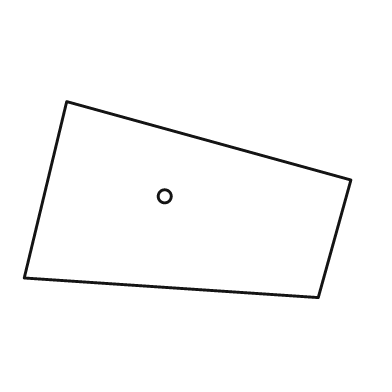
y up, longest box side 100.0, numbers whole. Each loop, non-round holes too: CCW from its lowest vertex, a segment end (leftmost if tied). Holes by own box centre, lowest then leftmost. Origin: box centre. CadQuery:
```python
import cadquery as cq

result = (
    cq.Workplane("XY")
    .moveTo(40.0, -30.0)
    .lineTo(50.0, 6.0)
    .lineTo(-37.0, 30.0)
    .lineTo(-50.0, -24.0)
    .close()
    .moveTo(-7.0, 1.0)
    .circle(2.0)
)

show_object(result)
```